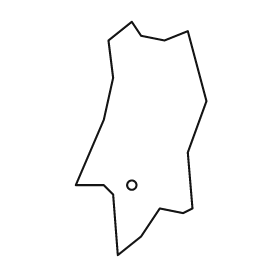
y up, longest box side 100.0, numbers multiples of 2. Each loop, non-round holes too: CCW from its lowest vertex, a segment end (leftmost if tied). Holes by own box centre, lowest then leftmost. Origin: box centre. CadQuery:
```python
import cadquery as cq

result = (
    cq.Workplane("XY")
    .moveTo(-10.0, -50.0)
    .lineTo(0.0, -42.0)
    .lineTo(8.0, -30.0)
    .lineTo(18.0, -32.0)
    .lineTo(22.0, -30.0)
    .lineTo(20.0, -6.0)
    .lineTo(28.0, 16.0)
    .lineTo(20.0, 46.0)
    .lineTo(10.0, 42.0)
    .lineTo(0.0, 44.0)
    .lineTo(-4.0, 50.0)
    .lineTo(-14.0, 42.0)
    .lineTo(-12.0, 26.0)
    .lineTo(-16.0, 8.0)
    .lineTo(-28.0, -20.0)
    .lineTo(-16.0, -20.0)
    .lineTo(-12.0, -24.0)
    .close()
    .moveTo(-4.0, -20.0)
    .circle(2.0)
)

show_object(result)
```